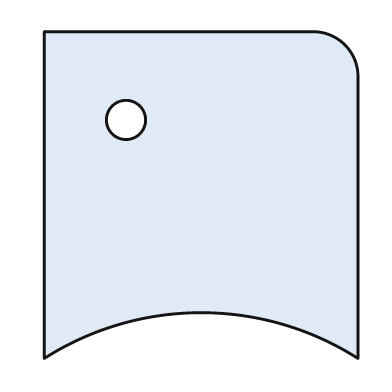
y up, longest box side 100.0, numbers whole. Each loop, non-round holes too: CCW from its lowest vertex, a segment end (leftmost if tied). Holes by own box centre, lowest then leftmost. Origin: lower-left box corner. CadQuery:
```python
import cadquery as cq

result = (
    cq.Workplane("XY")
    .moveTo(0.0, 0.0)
    .threePointArc((48.0, 14.0), (96.0, 0.0))
    .lineTo(96.0, 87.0)
    .threePointArc((92.0, 96.0), (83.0, 100.0))
    .lineTo(0.0, 100.0)
    .close()
    .moveTo(25.0, 73.0)
    .circle(6.0)
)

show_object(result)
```